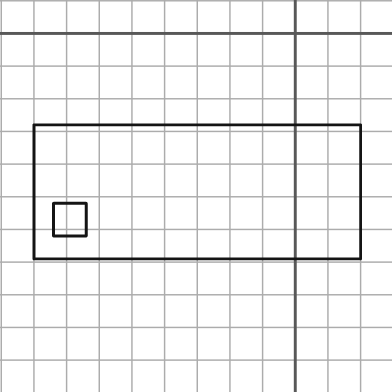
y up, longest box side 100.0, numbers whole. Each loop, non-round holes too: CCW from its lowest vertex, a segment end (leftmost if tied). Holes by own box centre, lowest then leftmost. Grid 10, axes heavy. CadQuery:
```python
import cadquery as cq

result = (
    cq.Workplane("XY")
    .moveTo(-80.0, -69.0)
    .lineTo(20.0, -69.0)
    .lineTo(20.0, -28.0)
    .lineTo(-80.0, -28.0)
    .close()
    .moveTo(-74.0, -62.0)
    .lineTo(-64.0, -62.0)
    .lineTo(-64.0, -52.0)
    .lineTo(-74.0, -52.0)
    .close()
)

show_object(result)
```